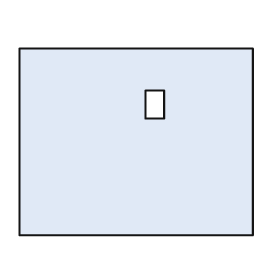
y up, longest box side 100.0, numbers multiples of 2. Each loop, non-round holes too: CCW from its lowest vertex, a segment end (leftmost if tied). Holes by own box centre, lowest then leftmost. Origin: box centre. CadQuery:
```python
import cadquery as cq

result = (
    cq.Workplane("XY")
    .moveTo(-50.0, -40.0)
    .lineTo(50.0, -40.0)
    .lineTo(50.0, 40.0)
    .lineTo(-50.0, 40.0)
    .close()
    .moveTo(4.0, 10.0)
    .lineTo(12.0, 10.0)
    .lineTo(12.0, 22.0)
    .lineTo(4.0, 22.0)
    .close()
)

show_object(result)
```